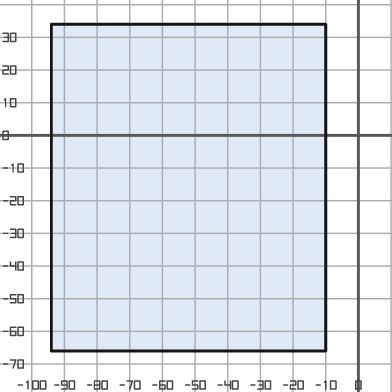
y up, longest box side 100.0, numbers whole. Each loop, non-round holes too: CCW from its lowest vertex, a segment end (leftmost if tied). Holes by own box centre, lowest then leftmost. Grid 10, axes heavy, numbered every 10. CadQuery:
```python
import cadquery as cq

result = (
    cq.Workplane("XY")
    .moveTo(-94.0, -66.0)
    .lineTo(-10.0, -66.0)
    .lineTo(-10.0, 34.0)
    .lineTo(-94.0, 34.0)
    .close()
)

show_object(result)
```